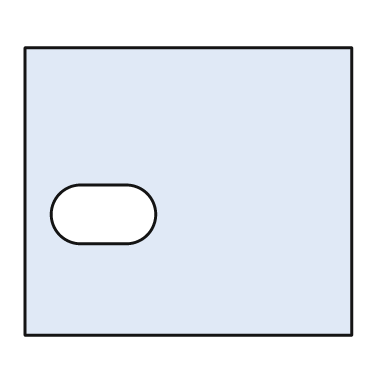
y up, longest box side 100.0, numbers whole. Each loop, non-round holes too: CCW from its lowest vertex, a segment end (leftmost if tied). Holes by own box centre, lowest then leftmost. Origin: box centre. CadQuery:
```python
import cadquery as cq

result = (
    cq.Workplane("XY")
    .moveTo(-50.0, -44.0)
    .lineTo(50.0, -44.0)
    .lineTo(50.0, 44.0)
    .lineTo(-50.0, 44.0)
    .close()
    .moveTo(-33.0, -16.0)
    .lineTo(-19.0, -16.0)
    .threePointArc((-10.0, -7.0), (-19.0, 2.0))
    .lineTo(-33.0, 2.0)
    .threePointArc((-42.0, -7.0), (-33.0, -16.0))
    .close()
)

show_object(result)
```